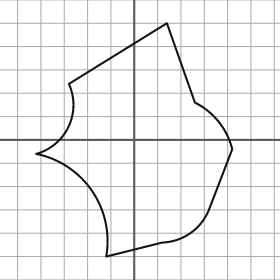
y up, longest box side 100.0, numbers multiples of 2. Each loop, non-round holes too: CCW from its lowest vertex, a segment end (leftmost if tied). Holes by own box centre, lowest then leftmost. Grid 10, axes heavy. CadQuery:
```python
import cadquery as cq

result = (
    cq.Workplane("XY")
    .moveTo(-12.0, -50.0)
    .lineTo(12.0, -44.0)
    .threePointArc((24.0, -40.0), (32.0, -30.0))
    .lineTo(42.0, -4.0)
    .threePointArc((36.0, 8.0), (26.0, 16.0))
    .lineTo(14.0, 50.0)
    .lineTo(-28.0, 24.0)
    .threePointArc((-28.0, 6.0), (-42.0, -6.0))
    .threePointArc((-18.0, -22.0), (-12.0, -50.0))
    .close()
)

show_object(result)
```